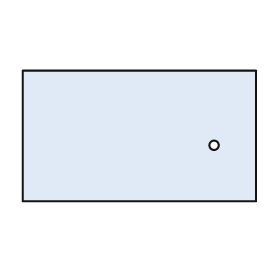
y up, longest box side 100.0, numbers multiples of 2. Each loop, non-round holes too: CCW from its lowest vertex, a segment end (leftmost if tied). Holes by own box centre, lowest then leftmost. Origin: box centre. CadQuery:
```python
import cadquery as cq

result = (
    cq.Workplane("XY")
    .moveTo(-50.0, -28.0)
    .lineTo(50.0, -28.0)
    .lineTo(50.0, 28.0)
    .lineTo(-50.0, 28.0)
    .close()
    .moveTo(32.0, -4.0)
    .circle(2.0)
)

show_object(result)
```